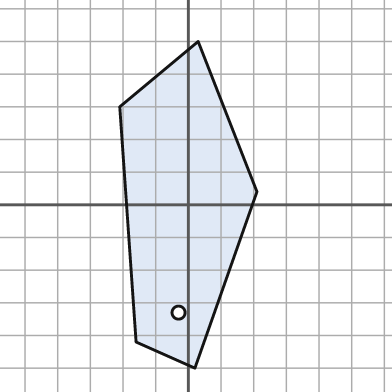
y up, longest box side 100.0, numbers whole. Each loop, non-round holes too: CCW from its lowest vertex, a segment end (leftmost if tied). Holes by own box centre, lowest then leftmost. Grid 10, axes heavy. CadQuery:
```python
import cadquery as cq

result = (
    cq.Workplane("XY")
    .moveTo(2.0, -50.0)
    .lineTo(21.0, 4.0)
    .lineTo(3.0, 50.0)
    .lineTo(-21.0, 30.0)
    .lineTo(-16.0, -42.0)
    .close()
    .moveTo(-3.0, -33.0)
    .circle(2.0)
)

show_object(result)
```